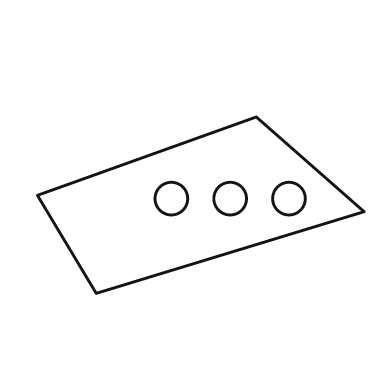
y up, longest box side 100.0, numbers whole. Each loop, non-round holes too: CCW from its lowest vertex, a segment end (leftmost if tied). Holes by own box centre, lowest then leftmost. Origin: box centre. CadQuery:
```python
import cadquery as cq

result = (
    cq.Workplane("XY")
    .moveTo(-32.0, -27.0)
    .lineTo(50.0, -2.0)
    .lineTo(17.0, 27.0)
    .lineTo(-50.0, 3.0)
    .close()
    .moveTo(-9.0, 2.0)
    .circle(5.0)
    .moveTo(9.0, 2.0)
    .circle(5.0)
    .moveTo(27.0, 2.0)
    .circle(5.0)
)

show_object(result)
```